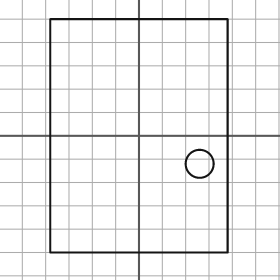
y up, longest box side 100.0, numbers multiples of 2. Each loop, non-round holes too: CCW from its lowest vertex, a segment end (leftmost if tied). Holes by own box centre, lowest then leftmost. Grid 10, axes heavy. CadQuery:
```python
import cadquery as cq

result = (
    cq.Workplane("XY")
    .moveTo(-38.0, -50.0)
    .lineTo(38.0, -50.0)
    .lineTo(38.0, 50.0)
    .lineTo(-38.0, 50.0)
    .close()
    .moveTo(26.0, -12.0)
    .circle(6.0)
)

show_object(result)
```